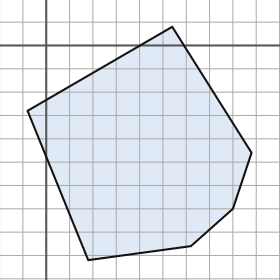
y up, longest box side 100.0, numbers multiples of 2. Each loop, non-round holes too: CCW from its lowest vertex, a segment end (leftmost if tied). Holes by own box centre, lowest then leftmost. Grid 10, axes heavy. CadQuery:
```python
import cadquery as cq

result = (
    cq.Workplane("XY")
    .moveTo(18.0, -92.0)
    .lineTo(62.0, -86.0)
    .lineTo(80.0, -70.0)
    .lineTo(88.0, -46.0)
    .lineTo(54.0, 8.0)
    .lineTo(-8.0, -28.0)
    .close()
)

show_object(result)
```